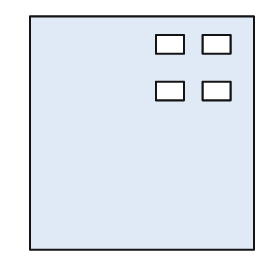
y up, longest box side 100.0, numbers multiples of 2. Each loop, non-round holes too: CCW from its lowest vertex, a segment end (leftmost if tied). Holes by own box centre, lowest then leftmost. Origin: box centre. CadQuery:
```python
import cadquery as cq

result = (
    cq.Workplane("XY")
    .moveTo(-48.0, -50.0)
    .lineTo(48.0, -50.0)
    .lineTo(48.0, 50.0)
    .lineTo(-48.0, 50.0)
    .close()
    .moveTo(6.0, 14.0)
    .lineTo(18.0, 14.0)
    .lineTo(18.0, 22.0)
    .lineTo(6.0, 22.0)
    .close()
    .moveTo(26.0, 14.0)
    .lineTo(38.0, 14.0)
    .lineTo(38.0, 22.0)
    .lineTo(26.0, 22.0)
    .close()
    .moveTo(6.0, 34.0)
    .lineTo(18.0, 34.0)
    .lineTo(18.0, 42.0)
    .lineTo(6.0, 42.0)
    .close()
    .moveTo(26.0, 34.0)
    .lineTo(38.0, 34.0)
    .lineTo(38.0, 42.0)
    .lineTo(26.0, 42.0)
    .close()
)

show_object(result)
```